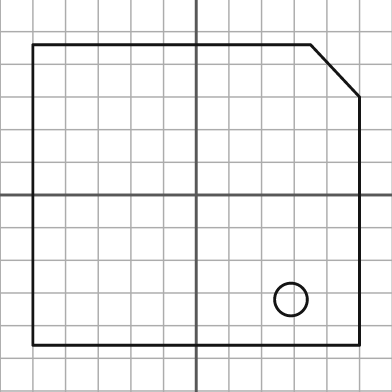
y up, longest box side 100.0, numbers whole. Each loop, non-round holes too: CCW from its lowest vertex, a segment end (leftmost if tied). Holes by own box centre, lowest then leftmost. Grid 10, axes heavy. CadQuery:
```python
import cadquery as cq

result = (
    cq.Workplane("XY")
    .moveTo(-50.0, -46.0)
    .lineTo(50.0, -46.0)
    .lineTo(50.0, 30.0)
    .lineTo(35.0, 46.0)
    .lineTo(-50.0, 46.0)
    .close()
    .moveTo(29.0, -32.0)
    .circle(5.0)
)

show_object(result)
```